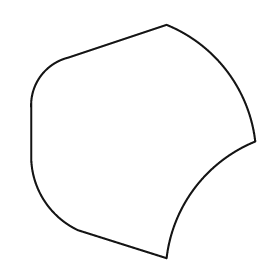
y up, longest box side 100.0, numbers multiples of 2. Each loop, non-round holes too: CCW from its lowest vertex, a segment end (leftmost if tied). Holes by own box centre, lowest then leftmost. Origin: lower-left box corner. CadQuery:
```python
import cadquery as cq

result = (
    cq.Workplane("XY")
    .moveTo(58.0, 0.0)
    .threePointArc((70.0, 30.0), (96.0, 50.0))
    .threePointArc((84.0, 80.0), (58.0, 100.0))
    .lineTo(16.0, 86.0)
    .threePointArc((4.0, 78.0), (0.0, 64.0))
    .lineTo(0.0, 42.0)
    .threePointArc((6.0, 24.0), (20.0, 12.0))
    .close()
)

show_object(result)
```